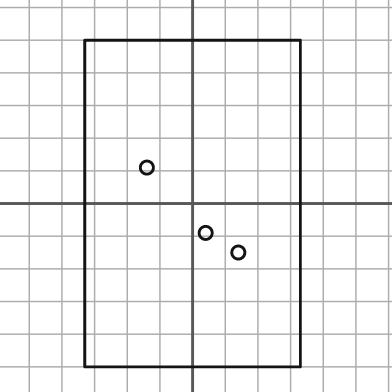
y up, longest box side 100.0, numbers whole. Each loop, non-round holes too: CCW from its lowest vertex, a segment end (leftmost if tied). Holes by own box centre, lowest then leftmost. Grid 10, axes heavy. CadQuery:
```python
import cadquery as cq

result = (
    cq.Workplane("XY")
    .moveTo(-33.0, -50.0)
    .lineTo(33.0, -50.0)
    .lineTo(33.0, 50.0)
    .lineTo(-33.0, 50.0)
    .close()
    .moveTo(14.0, -15.0)
    .circle(2.0)
    .moveTo(4.0, -9.0)
    .circle(2.0)
    .moveTo(-14.0, 11.0)
    .circle(2.0)
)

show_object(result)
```